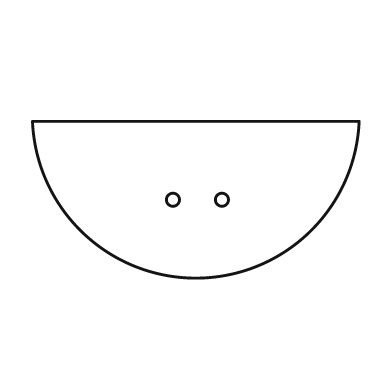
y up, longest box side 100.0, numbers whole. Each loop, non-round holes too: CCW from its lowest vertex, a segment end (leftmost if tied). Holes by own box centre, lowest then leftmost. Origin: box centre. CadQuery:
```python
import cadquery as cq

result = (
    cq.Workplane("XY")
    .moveTo(-50.0, 24.0)
    .threePointArc((0.0, -24.0), (50.0, 24.0))
    .close()
    .moveTo(-7.0, 0.0)
    .circle(2.0)
    .moveTo(8.0, 0.0)
    .circle(2.0)
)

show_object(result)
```